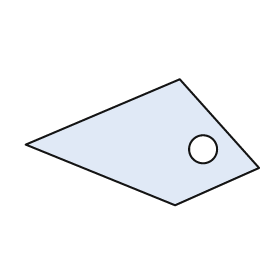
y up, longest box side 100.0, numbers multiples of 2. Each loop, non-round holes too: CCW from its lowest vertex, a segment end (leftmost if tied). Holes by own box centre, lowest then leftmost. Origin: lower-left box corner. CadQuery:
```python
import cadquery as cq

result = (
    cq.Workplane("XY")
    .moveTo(64.0, 0.0)
    .lineTo(100.0, 16.0)
    .lineTo(66.0, 54.0)
    .lineTo(0.0, 26.0)
    .close()
    .moveTo(76.0, 24.0)
    .circle(6.0)
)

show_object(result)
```